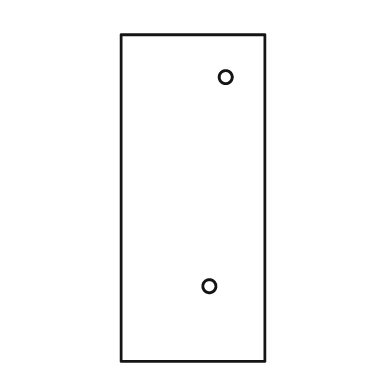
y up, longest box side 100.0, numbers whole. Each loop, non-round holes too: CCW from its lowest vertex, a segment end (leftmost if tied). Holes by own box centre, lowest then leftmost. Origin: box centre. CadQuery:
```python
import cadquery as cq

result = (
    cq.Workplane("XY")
    .moveTo(-22.0, -50.0)
    .lineTo(22.0, -50.0)
    .lineTo(22.0, 50.0)
    .lineTo(-22.0, 50.0)
    .close()
    .moveTo(5.0, -27.0)
    .circle(2.0)
    .moveTo(10.0, 37.0)
    .circle(2.0)
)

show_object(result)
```